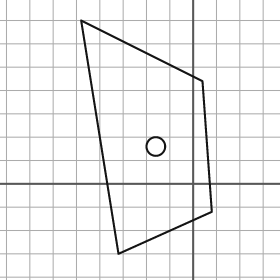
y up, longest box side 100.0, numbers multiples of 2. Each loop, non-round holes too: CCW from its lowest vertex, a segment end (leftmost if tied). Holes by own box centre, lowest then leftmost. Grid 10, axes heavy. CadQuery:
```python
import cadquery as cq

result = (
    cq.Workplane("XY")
    .moveTo(-32.0, -30.0)
    .lineTo(8.0, -12.0)
    .lineTo(4.0, 44.0)
    .lineTo(-48.0, 70.0)
    .close()
    .moveTo(-16.0, 16.0)
    .circle(4.0)
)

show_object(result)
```